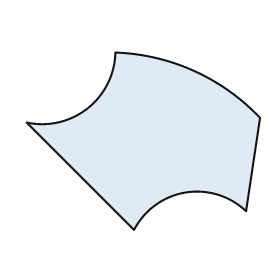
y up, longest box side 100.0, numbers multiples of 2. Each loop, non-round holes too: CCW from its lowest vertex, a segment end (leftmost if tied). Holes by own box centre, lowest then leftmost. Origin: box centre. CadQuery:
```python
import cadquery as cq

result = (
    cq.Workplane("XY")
    .moveTo(-4.0, -38.0)
    .threePointArc((18.0, -22.0), (44.0, -30.0))
    .lineTo(50.0, 10.0)
    .threePointArc((22.0, 30.0), (-12.0, 38.0))
    .threePointArc((-24.0, 14.0), (-50.0, 8.0))
    .close()
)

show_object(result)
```